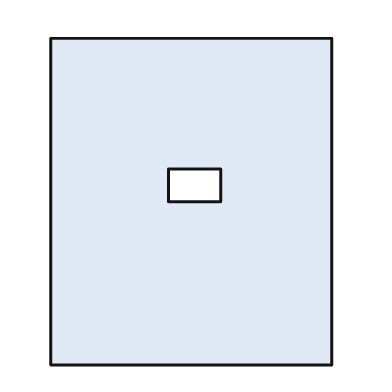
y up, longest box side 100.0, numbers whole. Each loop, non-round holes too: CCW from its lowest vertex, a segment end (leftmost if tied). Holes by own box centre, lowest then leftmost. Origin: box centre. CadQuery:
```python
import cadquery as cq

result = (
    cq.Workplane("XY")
    .moveTo(-43.0, -50.0)
    .lineTo(43.0, -50.0)
    .lineTo(43.0, 50.0)
    .lineTo(-43.0, 50.0)
    .close()
    .moveTo(-7.0, 0.0)
    .lineTo(9.0, 0.0)
    .lineTo(9.0, 10.0)
    .lineTo(-7.0, 10.0)
    .close()
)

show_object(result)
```